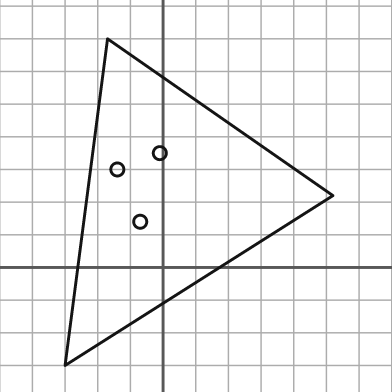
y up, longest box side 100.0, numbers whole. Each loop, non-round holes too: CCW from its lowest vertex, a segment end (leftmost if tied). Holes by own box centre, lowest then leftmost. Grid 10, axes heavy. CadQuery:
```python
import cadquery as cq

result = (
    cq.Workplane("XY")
    .moveTo(-30.0, -30.0)
    .lineTo(52.0, 22.0)
    .lineTo(-17.0, 70.0)
    .close()
    .moveTo(-7.0, 14.0)
    .circle(2.0)
    .moveTo(-14.0, 30.0)
    .circle(2.0)
    .moveTo(-1.0, 35.0)
    .circle(2.0)
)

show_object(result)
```